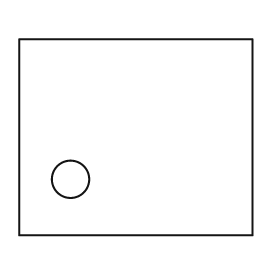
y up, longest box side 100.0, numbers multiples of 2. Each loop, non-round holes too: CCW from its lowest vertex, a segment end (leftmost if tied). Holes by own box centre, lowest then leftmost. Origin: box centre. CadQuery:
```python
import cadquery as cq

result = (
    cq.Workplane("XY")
    .moveTo(-50.0, -42.0)
    .lineTo(50.0, -42.0)
    .lineTo(50.0, 42.0)
    .lineTo(-50.0, 42.0)
    .close()
    .moveTo(-28.0, -18.0)
    .circle(8.0)
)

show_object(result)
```